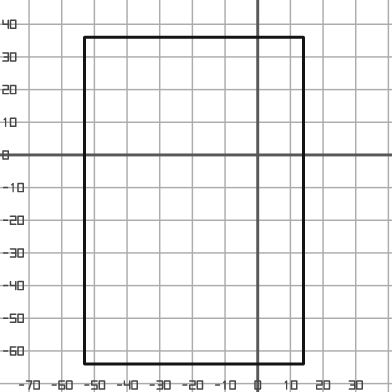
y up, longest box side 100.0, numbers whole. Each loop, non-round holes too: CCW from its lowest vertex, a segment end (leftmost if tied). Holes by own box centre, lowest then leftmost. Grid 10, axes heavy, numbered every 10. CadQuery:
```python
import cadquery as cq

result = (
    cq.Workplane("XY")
    .moveTo(-53.0, -64.0)
    .lineTo(14.0, -64.0)
    .lineTo(14.0, 36.0)
    .lineTo(-53.0, 36.0)
    .close()
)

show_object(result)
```